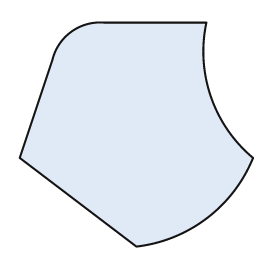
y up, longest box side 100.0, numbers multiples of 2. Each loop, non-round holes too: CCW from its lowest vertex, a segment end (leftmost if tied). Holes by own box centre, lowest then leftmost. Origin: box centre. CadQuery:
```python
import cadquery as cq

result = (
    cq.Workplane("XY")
    .moveTo(0.0, -48.0)
    .threePointArc((30.0, -36.0), (50.0, -10.0))
    .threePointArc((32.0, 16.0), (30.0, 48.0))
    .lineTo(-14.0, 48.0)
    .threePointArc((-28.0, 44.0), (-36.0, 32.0))
    .lineTo(-50.0, -10.0)
    .close()
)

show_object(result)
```